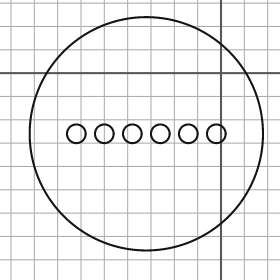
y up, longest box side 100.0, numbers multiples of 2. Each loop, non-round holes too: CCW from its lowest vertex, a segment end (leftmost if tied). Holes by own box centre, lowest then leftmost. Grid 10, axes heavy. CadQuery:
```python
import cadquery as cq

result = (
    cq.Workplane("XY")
    .moveTo(-32.0, -26.0)
    .circle(50.0)
    .moveTo(-62.0, -26.0)
    .circle(4.0)
    .moveTo(-50.0, -26.0)
    .circle(4.0)
    .moveTo(-38.0, -26.0)
    .circle(4.0)
    .moveTo(-26.0, -26.0)
    .circle(4.0)
    .moveTo(-14.0, -26.0)
    .circle(4.0)
    .moveTo(-2.0, -26.0)
    .circle(4.0)
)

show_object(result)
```